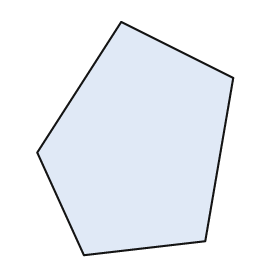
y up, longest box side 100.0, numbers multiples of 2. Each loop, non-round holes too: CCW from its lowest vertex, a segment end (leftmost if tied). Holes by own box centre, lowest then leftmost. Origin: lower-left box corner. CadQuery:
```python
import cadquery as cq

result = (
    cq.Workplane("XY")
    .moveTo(20.0, 0.0)
    .lineTo(72.0, 6.0)
    .lineTo(84.0, 76.0)
    .lineTo(36.0, 100.0)
    .lineTo(0.0, 44.0)
    .close()
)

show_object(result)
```